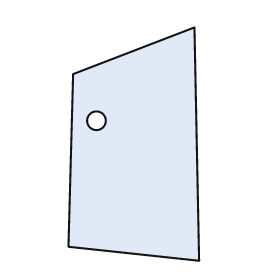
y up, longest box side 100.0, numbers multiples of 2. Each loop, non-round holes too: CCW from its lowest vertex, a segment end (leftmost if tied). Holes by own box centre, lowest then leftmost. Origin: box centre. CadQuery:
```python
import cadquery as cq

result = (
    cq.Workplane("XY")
    .moveTo(28.0, -50.0)
    .lineTo(26.0, 50.0)
    .lineTo(-26.0, 30.0)
    .lineTo(-28.0, -44.0)
    .close()
    .moveTo(-16.0, 10.0)
    .circle(4.0)
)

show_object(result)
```